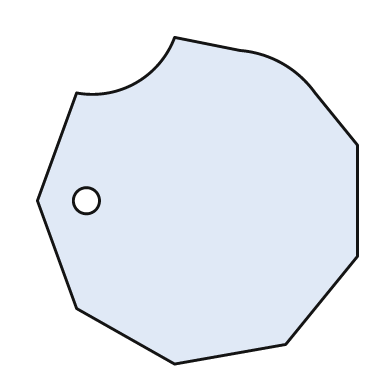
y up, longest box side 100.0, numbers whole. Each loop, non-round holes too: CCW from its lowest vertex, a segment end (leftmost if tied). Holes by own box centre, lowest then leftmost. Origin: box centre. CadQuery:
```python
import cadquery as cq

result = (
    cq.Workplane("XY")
    .moveTo(-7.0, -50.0)
    .lineTo(27.0, -44.0)
    .lineTo(49.0, -17.0)
    .lineTo(49.0, 17.0)
    .lineTo(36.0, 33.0)
    .threePointArc((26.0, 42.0), (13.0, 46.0))
    .lineTo(-7.0, 50.0)
    .threePointArc((-19.0, 36.0), (-37.0, 33.0))
    .lineTo(-49.0, 0.0)
    .lineTo(-37.0, -33.0)
    .close()
    .moveTo(-34.0, 0.0)
    .circle(4.0)
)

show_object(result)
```